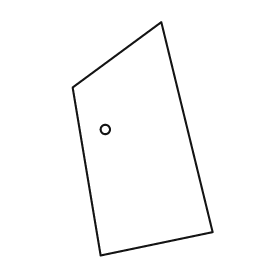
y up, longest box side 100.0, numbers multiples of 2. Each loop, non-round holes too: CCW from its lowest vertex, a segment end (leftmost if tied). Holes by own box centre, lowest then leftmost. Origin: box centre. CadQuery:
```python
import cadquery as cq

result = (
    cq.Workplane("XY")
    .moveTo(-18.0, -50.0)
    .lineTo(30.0, -40.0)
    .lineTo(8.0, 50.0)
    .lineTo(-30.0, 22.0)
    .close()
    .moveTo(-16.0, 4.0)
    .circle(2.0)
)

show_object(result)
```